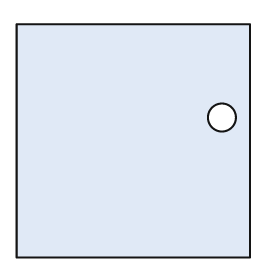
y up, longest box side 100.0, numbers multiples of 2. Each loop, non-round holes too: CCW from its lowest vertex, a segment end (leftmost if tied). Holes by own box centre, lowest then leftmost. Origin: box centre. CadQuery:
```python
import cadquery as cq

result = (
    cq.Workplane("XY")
    .moveTo(-50.0, -50.0)
    .lineTo(50.0, -50.0)
    .lineTo(50.0, 50.0)
    .lineTo(-50.0, 50.0)
    .close()
    .moveTo(38.0, 10.0)
    .circle(6.0)
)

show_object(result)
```